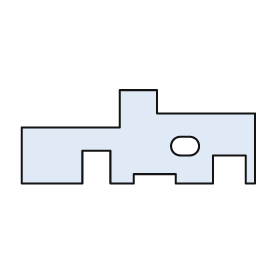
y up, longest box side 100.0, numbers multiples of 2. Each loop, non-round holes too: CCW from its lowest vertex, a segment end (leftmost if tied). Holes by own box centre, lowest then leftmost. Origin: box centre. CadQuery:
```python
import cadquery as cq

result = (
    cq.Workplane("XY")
    .moveTo(-50.0, -20.0)
    .lineTo(-24.0, -20.0)
    .lineTo(-24.0, -6.0)
    .lineTo(-12.0, -6.0)
    .lineTo(-12.0, -20.0)
    .lineTo(-2.0, -20.0)
    .lineTo(-2.0, -16.0)
    .lineTo(16.0, -16.0)
    .lineTo(16.0, -20.0)
    .lineTo(32.0, -20.0)
    .lineTo(32.0, -8.0)
    .lineTo(46.0, -8.0)
    .lineTo(46.0, -20.0)
    .lineTo(50.0, -20.0)
    .lineTo(50.0, 10.0)
    .lineTo(8.0, 10.0)
    .lineTo(8.0, 20.0)
    .lineTo(-8.0, 20.0)
    .lineTo(-8.0, 4.0)
    .lineTo(-50.0, 4.0)
    .close()
    .moveTo(18.0, -8.0)
    .lineTo(22.0, -8.0)
    .threePointArc((26.0, -4.0), (22.0, 0.0))
    .lineTo(18.0, 0.0)
    .threePointArc((14.0, -4.0), (18.0, -8.0))
    .close()
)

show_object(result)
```